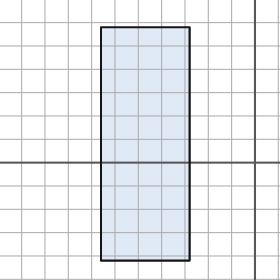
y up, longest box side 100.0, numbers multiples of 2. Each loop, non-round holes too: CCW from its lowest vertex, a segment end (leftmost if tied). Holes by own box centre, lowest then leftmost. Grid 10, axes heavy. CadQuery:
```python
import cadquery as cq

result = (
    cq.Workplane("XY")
    .moveTo(-66.0, -42.0)
    .lineTo(-28.0, -42.0)
    .lineTo(-28.0, 58.0)
    .lineTo(-66.0, 58.0)
    .close()
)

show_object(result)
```